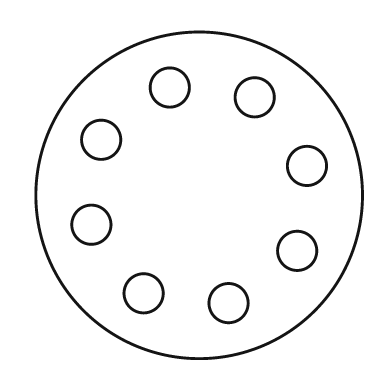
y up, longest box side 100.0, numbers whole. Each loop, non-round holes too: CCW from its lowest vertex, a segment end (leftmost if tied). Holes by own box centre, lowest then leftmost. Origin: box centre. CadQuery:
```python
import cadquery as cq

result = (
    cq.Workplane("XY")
    .moveTo(0.0, 0.0)
    .circle(50.0)
    .moveTo(9.0, -33.0)
    .circle(6.0)
    .moveTo(-17.0, -30.0)
    .circle(6.0)
    .moveTo(30.0, -17.0)
    .circle(6.0)
    .moveTo(-33.0, -9.0)
    .circle(6.0)
    .moveTo(33.0, 9.0)
    .circle(6.0)
    .moveTo(-30.0, 17.0)
    .circle(6.0)
    .moveTo(17.0, 30.0)
    .circle(6.0)
    .moveTo(-9.0, 33.0)
    .circle(6.0)
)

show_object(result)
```